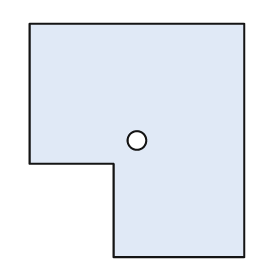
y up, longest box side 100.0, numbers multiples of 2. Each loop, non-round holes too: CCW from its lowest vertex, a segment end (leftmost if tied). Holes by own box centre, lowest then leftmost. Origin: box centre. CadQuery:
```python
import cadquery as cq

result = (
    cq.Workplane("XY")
    .moveTo(-10.0, -50.0)
    .lineTo(46.0, -50.0)
    .lineTo(46.0, 50.0)
    .lineTo(-46.0, 50.0)
    .lineTo(-46.0, -10.0)
    .lineTo(-10.0, -10.0)
    .close()
    .moveTo(0.0, 0.0)
    .circle(4.0)
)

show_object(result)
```